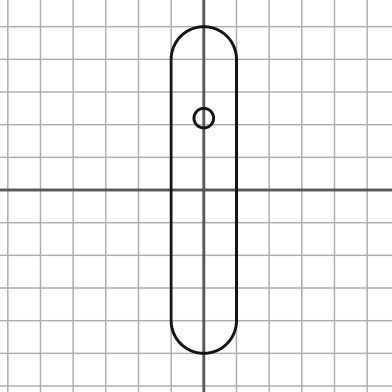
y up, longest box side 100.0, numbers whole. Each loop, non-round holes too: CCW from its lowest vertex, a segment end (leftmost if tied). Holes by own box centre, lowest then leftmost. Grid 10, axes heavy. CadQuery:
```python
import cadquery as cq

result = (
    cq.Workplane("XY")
    .moveTo(-10.0, -40.0)
    .threePointArc((0.0, -50.0), (10.0, -40.0))
    .lineTo(10.0, 40.0)
    .threePointArc((0.0, 50.0), (-10.0, 40.0))
    .close()
    .moveTo(0.0, 22.0)
    .circle(3.0)
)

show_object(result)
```